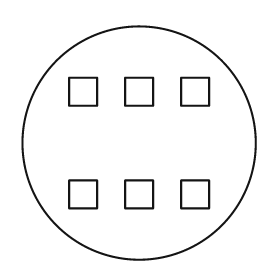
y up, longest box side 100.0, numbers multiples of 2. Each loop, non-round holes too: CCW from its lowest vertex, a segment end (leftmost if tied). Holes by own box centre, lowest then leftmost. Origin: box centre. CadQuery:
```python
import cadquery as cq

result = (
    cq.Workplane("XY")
    .moveTo(0.0, 0.0)
    .circle(50.0)
    .moveTo(-30.0, -28.0)
    .lineTo(-18.0, -28.0)
    .lineTo(-18.0, -16.0)
    .lineTo(-30.0, -16.0)
    .close()
    .moveTo(-6.0, -28.0)
    .lineTo(6.0, -28.0)
    .lineTo(6.0, -16.0)
    .lineTo(-6.0, -16.0)
    .close()
    .moveTo(18.0, -28.0)
    .lineTo(30.0, -28.0)
    .lineTo(30.0, -16.0)
    .lineTo(18.0, -16.0)
    .close()
    .moveTo(-30.0, 16.0)
    .lineTo(-18.0, 16.0)
    .lineTo(-18.0, 28.0)
    .lineTo(-30.0, 28.0)
    .close()
    .moveTo(-6.0, 16.0)
    .lineTo(6.0, 16.0)
    .lineTo(6.0, 28.0)
    .lineTo(-6.0, 28.0)
    .close()
    .moveTo(18.0, 16.0)
    .lineTo(30.0, 16.0)
    .lineTo(30.0, 28.0)
    .lineTo(18.0, 28.0)
    .close()
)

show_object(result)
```